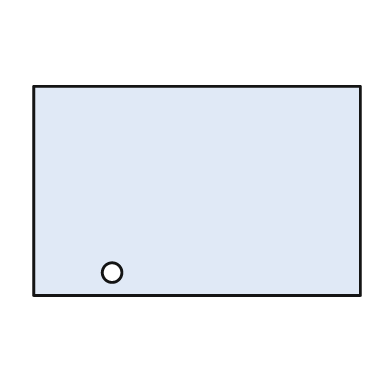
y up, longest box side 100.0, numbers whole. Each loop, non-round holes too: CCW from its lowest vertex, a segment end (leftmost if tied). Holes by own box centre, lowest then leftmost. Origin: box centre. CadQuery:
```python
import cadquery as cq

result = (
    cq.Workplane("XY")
    .moveTo(-50.0, -32.0)
    .lineTo(50.0, -32.0)
    .lineTo(50.0, 32.0)
    .lineTo(-50.0, 32.0)
    .close()
    .moveTo(-26.0, -25.0)
    .circle(3.0)
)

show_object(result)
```